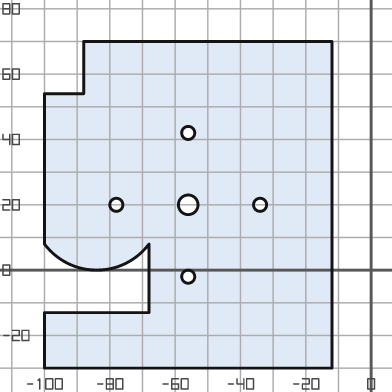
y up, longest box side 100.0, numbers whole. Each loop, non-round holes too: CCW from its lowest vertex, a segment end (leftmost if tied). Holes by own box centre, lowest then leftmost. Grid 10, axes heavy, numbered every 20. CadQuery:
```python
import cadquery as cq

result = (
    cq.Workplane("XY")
    .moveTo(-100.0, -30.0)
    .lineTo(-12.0, -30.0)
    .lineTo(-12.0, 70.0)
    .lineTo(-88.0, 70.0)
    .lineTo(-88.0, 54.0)
    .lineTo(-100.0, 54.0)
    .lineTo(-100.0, 8.0)
    .threePointArc((-84.0, 0.0), (-68.0, 8.0))
    .lineTo(-68.0, -13.0)
    .lineTo(-100.0, -13.0)
    .close()
    .moveTo(-56.0, -2.0)
    .circle(2.0)
    .moveTo(-78.0, 20.0)
    .circle(2.0)
    .moveTo(-56.0, 20.0)
    .circle(3.0)
    .moveTo(-34.0, 20.0)
    .circle(2.0)
    .moveTo(-56.0, 42.0)
    .circle(2.0)
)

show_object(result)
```